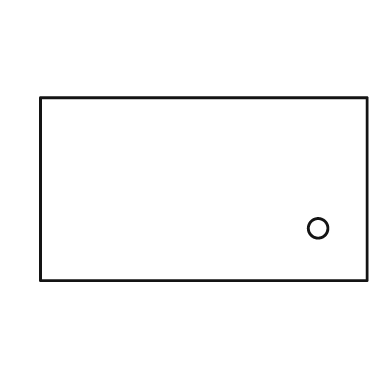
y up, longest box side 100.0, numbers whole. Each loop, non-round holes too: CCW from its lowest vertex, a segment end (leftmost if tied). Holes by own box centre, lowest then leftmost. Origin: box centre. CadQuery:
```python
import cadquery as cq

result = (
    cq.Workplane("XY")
    .moveTo(-50.0, -28.0)
    .lineTo(50.0, -28.0)
    .lineTo(50.0, 28.0)
    .lineTo(-50.0, 28.0)
    .close()
    .moveTo(35.0, -12.0)
    .circle(3.0)
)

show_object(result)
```